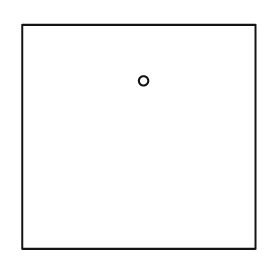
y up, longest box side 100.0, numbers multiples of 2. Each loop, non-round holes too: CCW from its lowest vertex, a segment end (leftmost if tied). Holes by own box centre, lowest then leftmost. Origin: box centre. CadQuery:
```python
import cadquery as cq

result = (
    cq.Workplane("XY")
    .moveTo(-50.0, -48.0)
    .lineTo(50.0, -48.0)
    .lineTo(50.0, 48.0)
    .lineTo(-50.0, 48.0)
    .close()
    .moveTo(2.0, 24.0)
    .circle(2.0)
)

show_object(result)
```